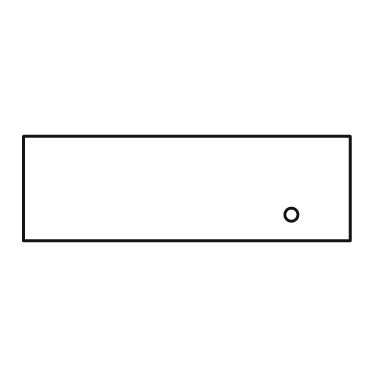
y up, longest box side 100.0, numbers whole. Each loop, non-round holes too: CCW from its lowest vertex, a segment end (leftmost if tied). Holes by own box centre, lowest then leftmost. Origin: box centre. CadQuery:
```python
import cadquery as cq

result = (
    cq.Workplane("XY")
    .moveTo(-50.0, -16.0)
    .lineTo(50.0, -16.0)
    .lineTo(50.0, 16.0)
    .lineTo(-50.0, 16.0)
    .close()
    .moveTo(32.0, -8.0)
    .circle(2.0)
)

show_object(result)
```